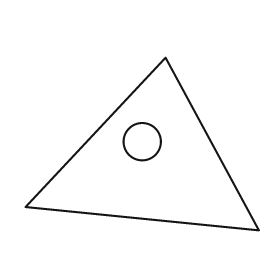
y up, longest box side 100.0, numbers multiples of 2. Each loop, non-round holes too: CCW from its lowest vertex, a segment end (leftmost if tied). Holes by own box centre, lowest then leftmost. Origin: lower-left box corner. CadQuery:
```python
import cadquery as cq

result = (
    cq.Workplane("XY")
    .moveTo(100.0, 0.0)
    .lineTo(60.0, 74.0)
    .lineTo(0.0, 10.0)
    .close()
    .moveTo(50.0, 38.0)
    .circle(8.0)
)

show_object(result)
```